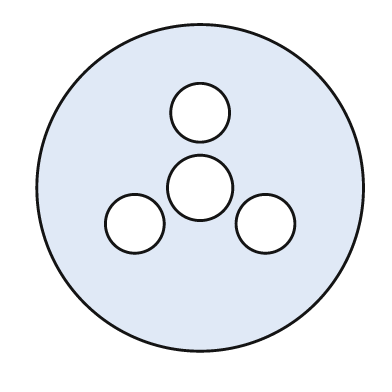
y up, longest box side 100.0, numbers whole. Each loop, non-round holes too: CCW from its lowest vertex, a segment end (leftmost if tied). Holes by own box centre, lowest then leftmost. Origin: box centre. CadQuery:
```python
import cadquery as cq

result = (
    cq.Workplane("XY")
    .moveTo(0.0, 0.0)
    .circle(50.0)
    .moveTo(-20.0, -11.0)
    .circle(9.0)
    .moveTo(20.0, -11.0)
    .circle(9.0)
    .moveTo(0.0, 0.0)
    .circle(10.0)
    .moveTo(0.0, 23.0)
    .circle(9.0)
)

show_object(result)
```